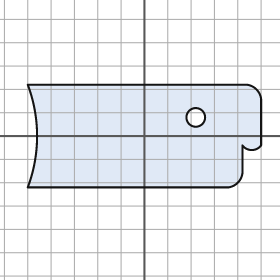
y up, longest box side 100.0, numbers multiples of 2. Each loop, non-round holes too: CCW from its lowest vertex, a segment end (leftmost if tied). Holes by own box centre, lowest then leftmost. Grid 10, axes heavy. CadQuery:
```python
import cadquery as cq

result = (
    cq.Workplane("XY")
    .moveTo(-50.0, -22.0)
    .lineTo(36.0, -22.0)
    .threePointArc((40.0, -20.0), (42.0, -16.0))
    .lineTo(42.0, -4.0)
    .threePointArc((46.0, -6.0), (50.0, -4.0))
    .lineTo(50.0, 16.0)
    .threePointArc((48.0, 20.0), (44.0, 22.0))
    .lineTo(-50.0, 22.0)
    .threePointArc((-46.0, 0.0), (-50.0, -22.0))
    .close()
    .moveTo(22.0, 8.0)
    .circle(4.0)
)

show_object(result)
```